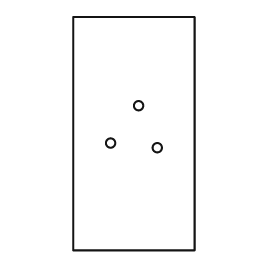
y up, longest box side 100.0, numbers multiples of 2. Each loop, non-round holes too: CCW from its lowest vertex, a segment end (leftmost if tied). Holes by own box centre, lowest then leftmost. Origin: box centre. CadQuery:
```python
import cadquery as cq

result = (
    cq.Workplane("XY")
    .moveTo(-26.0, -50.0)
    .lineTo(26.0, -50.0)
    .lineTo(26.0, 50.0)
    .lineTo(-26.0, 50.0)
    .close()
    .moveTo(10.0, -6.0)
    .circle(2.0)
    .moveTo(-10.0, -4.0)
    .circle(2.0)
    .moveTo(2.0, 12.0)
    .circle(2.0)
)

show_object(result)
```